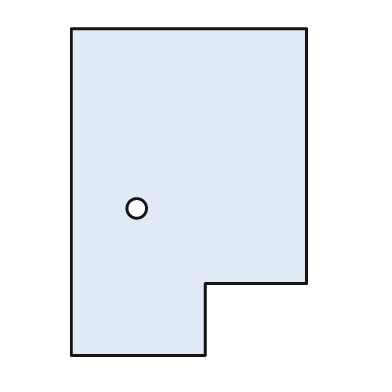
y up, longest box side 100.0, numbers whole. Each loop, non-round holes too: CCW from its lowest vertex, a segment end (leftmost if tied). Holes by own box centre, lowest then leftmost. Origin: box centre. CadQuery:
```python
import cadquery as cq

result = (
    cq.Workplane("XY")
    .moveTo(-36.0, -50.0)
    .lineTo(5.0, -50.0)
    .lineTo(5.0, -28.0)
    .lineTo(36.0, -28.0)
    .lineTo(36.0, 50.0)
    .lineTo(-36.0, 50.0)
    .close()
    .moveTo(-16.0, -5.0)
    .circle(3.0)
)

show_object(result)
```